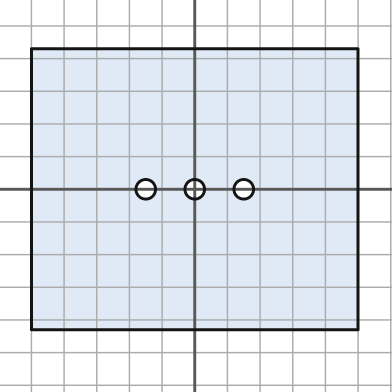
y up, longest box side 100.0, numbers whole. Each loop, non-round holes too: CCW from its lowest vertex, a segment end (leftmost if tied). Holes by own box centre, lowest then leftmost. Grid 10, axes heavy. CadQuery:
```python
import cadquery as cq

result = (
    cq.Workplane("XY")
    .moveTo(-50.0, -43.0)
    .lineTo(50.0, -43.0)
    .lineTo(50.0, 43.0)
    .lineTo(-50.0, 43.0)
    .close()
    .moveTo(-15.0, 0.0)
    .circle(3.0)
    .moveTo(0.0, 0.0)
    .circle(3.0)
    .moveTo(15.0, 0.0)
    .circle(3.0)
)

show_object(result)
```